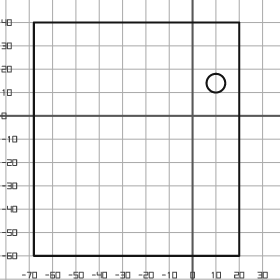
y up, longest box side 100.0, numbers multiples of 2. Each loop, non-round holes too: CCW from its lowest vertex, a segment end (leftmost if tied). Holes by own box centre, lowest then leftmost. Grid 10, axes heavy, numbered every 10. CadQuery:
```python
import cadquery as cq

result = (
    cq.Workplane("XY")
    .moveTo(-68.0, -60.0)
    .lineTo(20.0, -60.0)
    .lineTo(20.0, 40.0)
    .lineTo(-68.0, 40.0)
    .close()
    .moveTo(10.0, 14.0)
    .circle(4.0)
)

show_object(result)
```